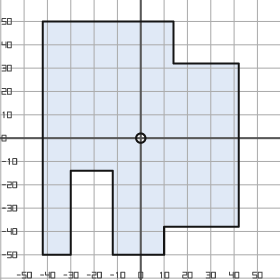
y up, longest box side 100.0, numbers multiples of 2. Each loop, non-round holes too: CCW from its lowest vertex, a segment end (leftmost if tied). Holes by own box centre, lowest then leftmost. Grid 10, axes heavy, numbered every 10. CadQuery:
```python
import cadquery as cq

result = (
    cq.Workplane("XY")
    .moveTo(-42.0, -50.0)
    .lineTo(-30.0, -50.0)
    .lineTo(-30.0, -14.0)
    .lineTo(-12.0, -14.0)
    .lineTo(-12.0, -50.0)
    .lineTo(10.0, -50.0)
    .lineTo(10.0, -38.0)
    .lineTo(42.0, -38.0)
    .lineTo(42.0, 32.0)
    .lineTo(14.0, 32.0)
    .lineTo(14.0, 50.0)
    .lineTo(-42.0, 50.0)
    .close()
    .moveTo(0.0, 0.0)
    .circle(2.0)
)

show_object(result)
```